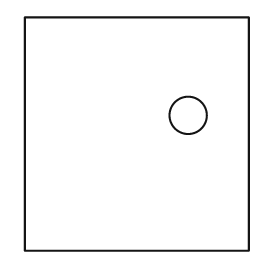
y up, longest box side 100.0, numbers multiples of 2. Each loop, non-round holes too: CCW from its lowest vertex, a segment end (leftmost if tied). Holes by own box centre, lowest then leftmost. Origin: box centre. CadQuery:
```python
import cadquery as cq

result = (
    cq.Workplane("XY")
    .moveTo(-48.0, -50.0)
    .lineTo(48.0, -50.0)
    .lineTo(48.0, 50.0)
    .lineTo(-48.0, 50.0)
    .close()
    .moveTo(22.0, 8.0)
    .circle(8.0)
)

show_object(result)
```